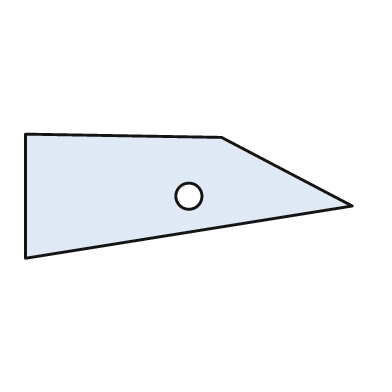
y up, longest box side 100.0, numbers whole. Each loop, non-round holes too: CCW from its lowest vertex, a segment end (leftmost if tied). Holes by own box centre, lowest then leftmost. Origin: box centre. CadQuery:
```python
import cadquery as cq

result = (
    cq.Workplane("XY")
    .moveTo(-50.0, -19.0)
    .lineTo(50.0, -3.0)
    .lineTo(10.0, 18.0)
    .lineTo(-50.0, 19.0)
    .close()
    .moveTo(0.0, 0.0)
    .circle(4.0)
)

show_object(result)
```